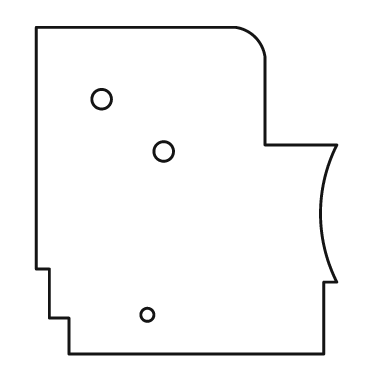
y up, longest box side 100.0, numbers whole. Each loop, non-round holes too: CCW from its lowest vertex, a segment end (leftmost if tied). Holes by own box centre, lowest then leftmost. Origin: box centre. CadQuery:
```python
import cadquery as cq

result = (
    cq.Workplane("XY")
    .moveTo(-36.0, -50.0)
    .lineTo(42.0, -50.0)
    .lineTo(42.0, -28.0)
    .lineTo(46.0, -28.0)
    .threePointArc((41.0, -7.0), (46.0, 14.0))
    .lineTo(24.0, 14.0)
    .lineTo(24.0, 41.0)
    .threePointArc((21.0, 47.0), (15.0, 50.0))
    .lineTo(-46.0, 50.0)
    .lineTo(-46.0, -24.0)
    .lineTo(-42.0, -24.0)
    .lineTo(-42.0, -39.0)
    .lineTo(-36.0, -39.0)
    .close()
    .moveTo(-12.0, -38.0)
    .circle(2.0)
    .moveTo(-7.0, 12.0)
    .circle(3.0)
    .moveTo(-26.0, 28.0)
    .circle(3.0)
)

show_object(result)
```